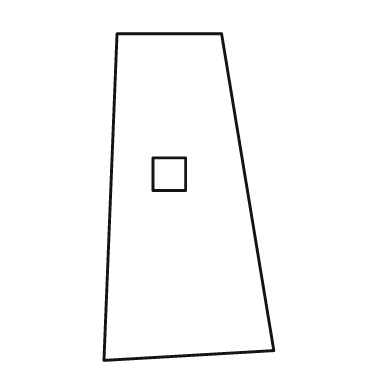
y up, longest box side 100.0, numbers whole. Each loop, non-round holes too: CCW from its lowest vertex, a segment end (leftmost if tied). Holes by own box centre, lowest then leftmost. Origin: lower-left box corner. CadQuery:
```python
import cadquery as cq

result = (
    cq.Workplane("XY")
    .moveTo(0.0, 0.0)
    .lineTo(52.0, 3.0)
    .lineTo(36.0, 100.0)
    .lineTo(4.0, 100.0)
    .close()
    .moveTo(15.0, 52.0)
    .lineTo(25.0, 52.0)
    .lineTo(25.0, 62.0)
    .lineTo(15.0, 62.0)
    .close()
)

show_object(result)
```